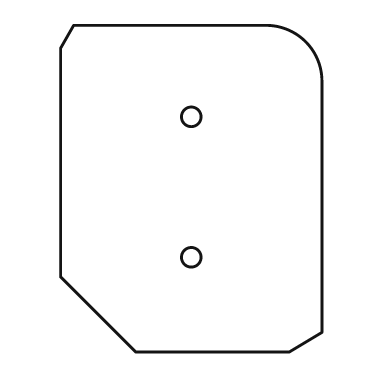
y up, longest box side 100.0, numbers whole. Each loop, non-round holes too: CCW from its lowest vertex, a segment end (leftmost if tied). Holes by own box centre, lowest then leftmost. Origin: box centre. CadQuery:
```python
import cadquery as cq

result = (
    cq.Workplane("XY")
    .moveTo(-17.0, -50.0)
    .lineTo(30.0, -50.0)
    .lineTo(40.0, -44.0)
    .lineTo(40.0, 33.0)
    .threePointArc((35.0, 45.0), (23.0, 50.0))
    .lineTo(-36.0, 50.0)
    .lineTo(-40.0, 43.0)
    .lineTo(-40.0, -27.0)
    .close()
    .moveTo(0.0, -21.0)
    .circle(3.0)
    .moveTo(0.0, 22.0)
    .circle(3.0)
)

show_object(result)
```